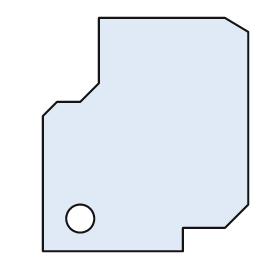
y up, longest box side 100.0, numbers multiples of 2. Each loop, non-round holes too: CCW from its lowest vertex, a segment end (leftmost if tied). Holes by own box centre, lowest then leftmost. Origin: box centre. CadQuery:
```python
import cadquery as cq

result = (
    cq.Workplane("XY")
    .moveTo(-44.0, -50.0)
    .lineTo(16.0, -50.0)
    .lineTo(16.0, -40.0)
    .lineTo(34.0, -40.0)
    .lineTo(44.0, -30.0)
    .lineTo(44.0, 44.0)
    .lineTo(34.0, 50.0)
    .lineTo(-20.0, 50.0)
    .lineTo(-20.0, 22.0)
    .lineTo(-28.0, 14.0)
    .lineTo(-38.0, 14.0)
    .lineTo(-44.0, 8.0)
    .close()
    .moveTo(-28.0, -36.0)
    .circle(6.0)
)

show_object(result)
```